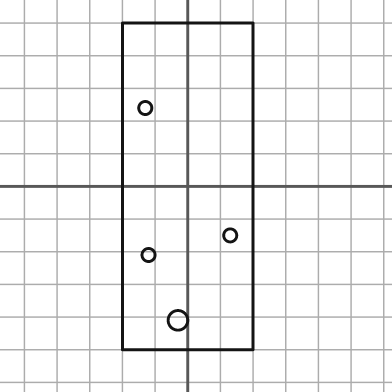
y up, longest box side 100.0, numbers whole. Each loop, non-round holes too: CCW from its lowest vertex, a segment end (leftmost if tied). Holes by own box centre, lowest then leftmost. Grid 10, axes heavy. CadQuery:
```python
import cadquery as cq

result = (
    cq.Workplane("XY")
    .moveTo(-20.0, -50.0)
    .lineTo(20.0, -50.0)
    .lineTo(20.0, 50.0)
    .lineTo(-20.0, 50.0)
    .close()
    .moveTo(-3.0, -41.0)
    .circle(3.0)
    .moveTo(-12.0, -21.0)
    .circle(2.0)
    .moveTo(13.0, -15.0)
    .circle(2.0)
    .moveTo(-13.0, 24.0)
    .circle(2.0)
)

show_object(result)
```